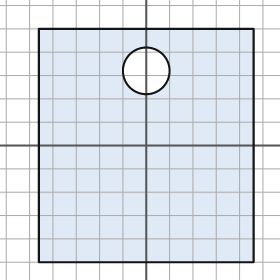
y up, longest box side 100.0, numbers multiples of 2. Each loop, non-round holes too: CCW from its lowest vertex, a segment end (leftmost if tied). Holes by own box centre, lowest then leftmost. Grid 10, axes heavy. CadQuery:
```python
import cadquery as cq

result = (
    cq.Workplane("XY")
    .moveTo(-46.0, -50.0)
    .lineTo(46.0, -50.0)
    .lineTo(46.0, 50.0)
    .lineTo(-46.0, 50.0)
    .close()
    .moveTo(0.0, 32.0)
    .circle(10.0)
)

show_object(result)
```